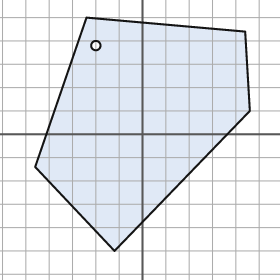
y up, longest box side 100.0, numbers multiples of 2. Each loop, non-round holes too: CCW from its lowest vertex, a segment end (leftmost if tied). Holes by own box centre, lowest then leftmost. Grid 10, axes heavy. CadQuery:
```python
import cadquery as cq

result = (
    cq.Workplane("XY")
    .moveTo(-12.0, -50.0)
    .lineTo(46.0, 10.0)
    .lineTo(44.0, 44.0)
    .lineTo(-24.0, 50.0)
    .lineTo(-46.0, -14.0)
    .close()
    .moveTo(-20.0, 38.0)
    .circle(2.0)
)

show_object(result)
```